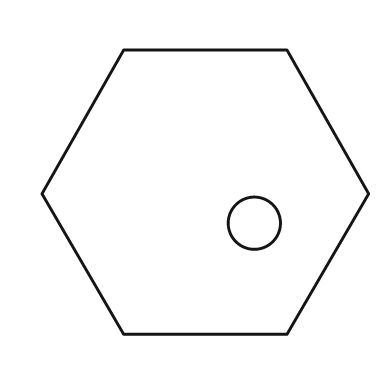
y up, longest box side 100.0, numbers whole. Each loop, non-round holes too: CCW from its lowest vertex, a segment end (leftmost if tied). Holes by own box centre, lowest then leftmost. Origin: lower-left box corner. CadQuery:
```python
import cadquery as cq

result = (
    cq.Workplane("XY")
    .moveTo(25.0, 0.0)
    .lineTo(75.0, 0.0)
    .lineTo(100.0, 43.0)
    .lineTo(75.0, 87.0)
    .lineTo(25.0, 87.0)
    .lineTo(0.0, 43.0)
    .close()
    .moveTo(65.0, 34.0)
    .circle(8.0)
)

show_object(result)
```